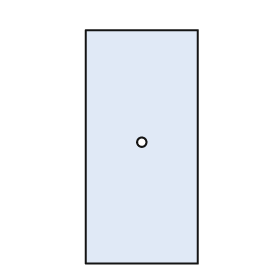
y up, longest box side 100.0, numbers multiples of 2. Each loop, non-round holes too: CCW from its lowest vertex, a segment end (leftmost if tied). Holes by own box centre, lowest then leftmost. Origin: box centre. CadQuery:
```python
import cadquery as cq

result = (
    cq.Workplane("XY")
    .moveTo(-24.0, -50.0)
    .lineTo(24.0, -50.0)
    .lineTo(24.0, 50.0)
    .lineTo(-24.0, 50.0)
    .close()
    .moveTo(0.0, 2.0)
    .circle(2.0)
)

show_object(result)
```